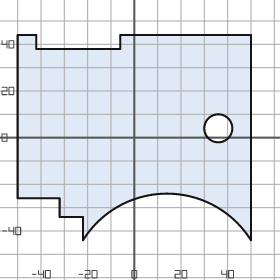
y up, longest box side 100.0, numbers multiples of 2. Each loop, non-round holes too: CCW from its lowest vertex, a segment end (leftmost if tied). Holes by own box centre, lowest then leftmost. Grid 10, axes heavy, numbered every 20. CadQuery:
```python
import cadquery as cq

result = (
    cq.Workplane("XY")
    .moveTo(-22.0, -44.0)
    .threePointArc((14.0, -24.0), (50.0, -44.0))
    .lineTo(50.0, 44.0)
    .lineTo(-6.0, 44.0)
    .lineTo(-6.0, 38.0)
    .lineTo(-42.0, 38.0)
    .lineTo(-42.0, 44.0)
    .lineTo(-50.0, 44.0)
    .lineTo(-50.0, -26.0)
    .lineTo(-32.0, -26.0)
    .lineTo(-32.0, -34.0)
    .lineTo(-22.0, -34.0)
    .close()
    .moveTo(36.0, 4.0)
    .circle(6.0)
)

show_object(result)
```